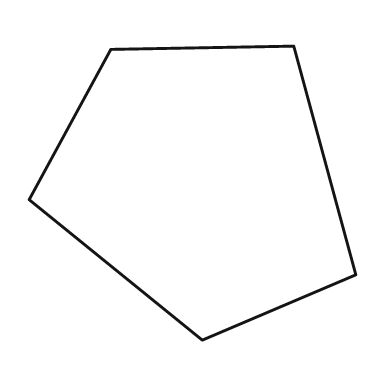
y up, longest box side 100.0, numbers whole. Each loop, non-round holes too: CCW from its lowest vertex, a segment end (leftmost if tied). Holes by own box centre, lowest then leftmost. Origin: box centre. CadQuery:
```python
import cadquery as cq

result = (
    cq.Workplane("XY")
    .moveTo(3.0, -45.0)
    .lineTo(50.0, -25.0)
    .lineTo(31.0, 45.0)
    .lineTo(-25.0, 44.0)
    .lineTo(-50.0, -2.0)
    .close()
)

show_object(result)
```